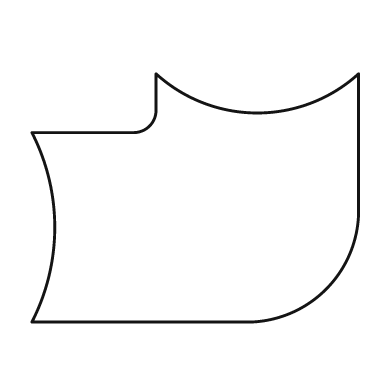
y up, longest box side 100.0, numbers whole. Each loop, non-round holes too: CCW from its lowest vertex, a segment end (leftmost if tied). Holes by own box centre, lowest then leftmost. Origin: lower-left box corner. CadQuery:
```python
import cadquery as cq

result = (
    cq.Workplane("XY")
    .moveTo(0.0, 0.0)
    .lineTo(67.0, 0.0)
    .threePointArc((90.0, 10.0), (100.0, 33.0))
    .lineTo(100.0, 76.0)
    .threePointArc((69.0, 64.0), (38.0, 76.0))
    .lineTo(38.0, 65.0)
    .threePointArc((36.0, 60.0), (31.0, 58.0))
    .lineTo(0.0, 58.0)
    .threePointArc((7.0, 29.0), (0.0, 0.0))
    .close()
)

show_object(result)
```